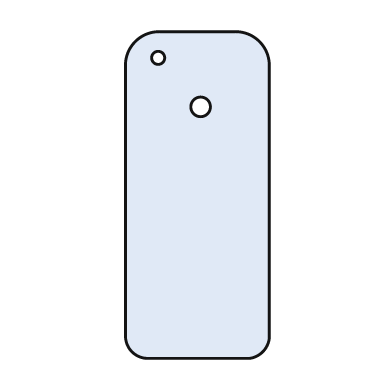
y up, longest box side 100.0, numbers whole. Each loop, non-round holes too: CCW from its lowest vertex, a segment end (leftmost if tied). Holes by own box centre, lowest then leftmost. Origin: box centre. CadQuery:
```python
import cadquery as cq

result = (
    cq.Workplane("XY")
    .moveTo(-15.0, -50.0)
    .lineTo(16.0, -50.0)
    .threePointArc((20.0, -48.0), (22.0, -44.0))
    .lineTo(22.0, 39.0)
    .threePointArc((19.0, 47.0), (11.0, 50.0))
    .lineTo(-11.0, 50.0)
    .threePointArc((-19.0, 47.0), (-22.0, 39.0))
    .lineTo(-22.0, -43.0)
    .threePointArc((-20.0, -48.0), (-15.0, -50.0))
    .close()
    .moveTo(1.0, 27.0)
    .circle(3.0)
    .moveTo(-12.0, 42.0)
    .circle(2.0)
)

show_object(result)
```